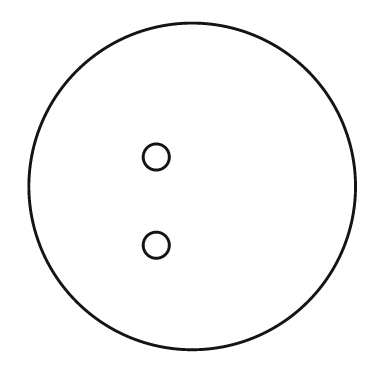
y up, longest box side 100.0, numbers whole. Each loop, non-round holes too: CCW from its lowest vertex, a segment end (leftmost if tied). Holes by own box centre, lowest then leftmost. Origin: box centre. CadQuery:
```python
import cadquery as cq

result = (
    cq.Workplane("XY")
    .moveTo(0.0, 0.0)
    .circle(50.0)
    .moveTo(-11.0, -18.0)
    .circle(4.0)
    .moveTo(-11.0, 9.0)
    .circle(4.0)
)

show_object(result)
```